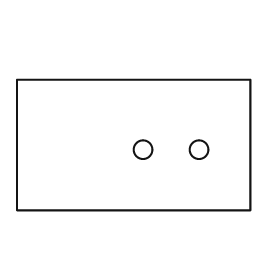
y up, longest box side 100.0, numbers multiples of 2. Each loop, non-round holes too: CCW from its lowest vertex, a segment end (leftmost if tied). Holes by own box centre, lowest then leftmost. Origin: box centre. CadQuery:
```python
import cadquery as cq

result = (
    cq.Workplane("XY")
    .moveTo(-50.0, -28.0)
    .lineTo(50.0, -28.0)
    .lineTo(50.0, 28.0)
    .lineTo(-50.0, 28.0)
    .close()
    .moveTo(4.0, -2.0)
    .circle(4.0)
    .moveTo(28.0, -2.0)
    .circle(4.0)
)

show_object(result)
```